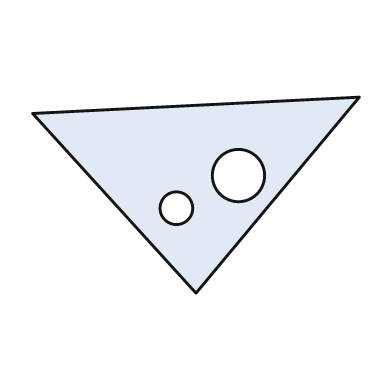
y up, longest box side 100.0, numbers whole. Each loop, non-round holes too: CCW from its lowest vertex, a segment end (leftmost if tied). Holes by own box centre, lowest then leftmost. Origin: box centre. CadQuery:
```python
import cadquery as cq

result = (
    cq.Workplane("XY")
    .moveTo(0.0, -30.0)
    .lineTo(50.0, 30.0)
    .lineTo(-50.0, 25.0)
    .close()
    .moveTo(-6.0, -4.0)
    .circle(5.0)
    .moveTo(13.0, 6.0)
    .circle(8.0)
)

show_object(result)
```